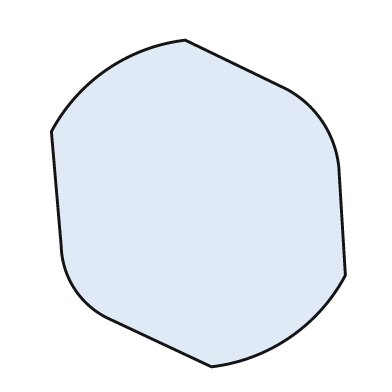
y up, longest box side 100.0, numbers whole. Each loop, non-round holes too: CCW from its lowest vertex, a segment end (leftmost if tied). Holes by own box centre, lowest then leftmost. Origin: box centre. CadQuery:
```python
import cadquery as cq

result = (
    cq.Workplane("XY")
    .moveTo(4.0, -50.0)
    .threePointArc((28.0, -41.0), (45.0, -22.0))
    .lineTo(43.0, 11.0)
    .threePointArc((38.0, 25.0), (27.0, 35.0))
    .lineTo(-4.0, 50.0)
    .threePointArc((-28.0, 41.0), (-45.0, 22.0))
    .lineTo(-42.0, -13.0)
    .threePointArc((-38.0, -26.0), (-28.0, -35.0))
    .close()
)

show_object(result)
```